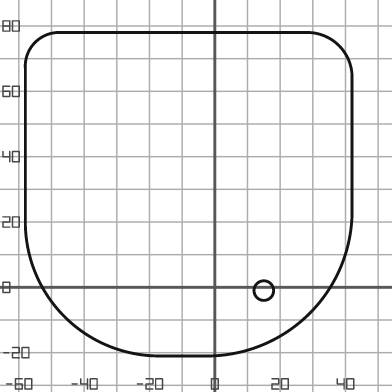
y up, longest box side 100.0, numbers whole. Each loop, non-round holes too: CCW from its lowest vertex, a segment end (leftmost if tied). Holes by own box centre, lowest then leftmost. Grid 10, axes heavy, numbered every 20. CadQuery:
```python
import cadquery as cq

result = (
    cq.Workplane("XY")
    .moveTo(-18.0, -21.0)
    .lineTo(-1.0, -21.0)
    .threePointArc((29.0, -8.0), (42.0, 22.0))
    .lineTo(42.0, 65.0)
    .threePointArc((38.0, 74.0), (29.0, 78.0))
    .lineTo(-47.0, 78.0)
    .threePointArc((-55.0, 75.0), (-58.0, 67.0))
    .lineTo(-58.0, 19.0)
    .threePointArc((-46.0, -9.0), (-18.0, -21.0))
    .close()
    .moveTo(15.0, -1.0)
    .circle(3.0)
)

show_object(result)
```